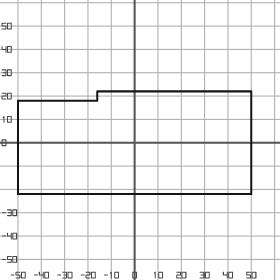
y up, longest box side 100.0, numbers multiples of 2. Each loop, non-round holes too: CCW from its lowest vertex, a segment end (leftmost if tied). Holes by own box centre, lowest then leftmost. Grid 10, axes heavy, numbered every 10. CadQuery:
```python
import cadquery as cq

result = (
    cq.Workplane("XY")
    .moveTo(-50.0, -22.0)
    .lineTo(50.0, -22.0)
    .lineTo(50.0, 22.0)
    .lineTo(-16.0, 22.0)
    .lineTo(-16.0, 18.0)
    .lineTo(-50.0, 18.0)
    .close()
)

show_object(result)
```